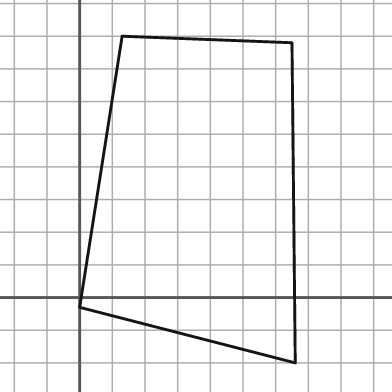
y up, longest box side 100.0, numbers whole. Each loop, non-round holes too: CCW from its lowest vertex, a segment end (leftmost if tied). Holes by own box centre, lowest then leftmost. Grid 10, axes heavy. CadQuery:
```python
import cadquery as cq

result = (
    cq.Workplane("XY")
    .moveTo(66.0, -20.0)
    .lineTo(65.0, 78.0)
    .lineTo(13.0, 80.0)
    .lineTo(0.0, -3.0)
    .close()
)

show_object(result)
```